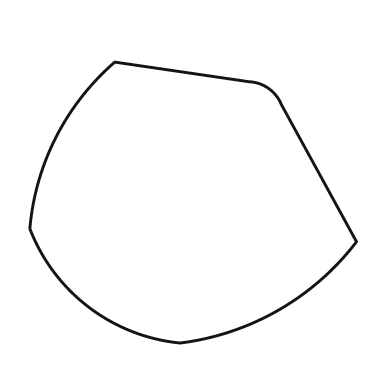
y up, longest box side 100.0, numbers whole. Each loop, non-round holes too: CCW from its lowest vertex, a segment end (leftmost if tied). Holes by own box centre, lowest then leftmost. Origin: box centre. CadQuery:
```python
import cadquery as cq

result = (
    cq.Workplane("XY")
    .moveTo(-4.0, -43.0)
    .threePointArc((26.0, -33.0), (50.0, -12.0))
    .lineTo(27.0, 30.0)
    .threePointArc((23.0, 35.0), (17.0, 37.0))
    .lineTo(-24.0, 43.0)
    .threePointArc((-42.0, 20.0), (-50.0, -8.0))
    .threePointArc((-32.0, -32.0), (-4.0, -43.0))
    .close()
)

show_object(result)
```